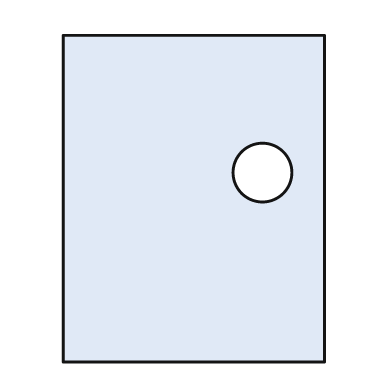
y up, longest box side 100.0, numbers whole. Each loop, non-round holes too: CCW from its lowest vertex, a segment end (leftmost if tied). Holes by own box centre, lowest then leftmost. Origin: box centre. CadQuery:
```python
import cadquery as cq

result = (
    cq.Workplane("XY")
    .moveTo(-40.0, -50.0)
    .lineTo(40.0, -50.0)
    .lineTo(40.0, 50.0)
    .lineTo(-40.0, 50.0)
    .close()
    .moveTo(21.0, 8.0)
    .circle(9.0)
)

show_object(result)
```